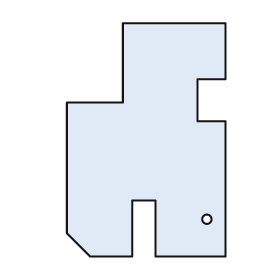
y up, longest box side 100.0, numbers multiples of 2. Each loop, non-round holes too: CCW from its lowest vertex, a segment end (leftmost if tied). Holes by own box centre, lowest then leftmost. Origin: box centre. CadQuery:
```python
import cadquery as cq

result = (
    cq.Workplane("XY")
    .moveTo(-24.0, -50.0)
    .lineTo(-6.0, -50.0)
    .lineTo(-6.0, -26.0)
    .lineTo(4.0, -26.0)
    .lineTo(4.0, -50.0)
    .lineTo(34.0, -50.0)
    .lineTo(34.0, 8.0)
    .lineTo(22.0, 8.0)
    .lineTo(22.0, 26.0)
    .lineTo(34.0, 26.0)
    .lineTo(34.0, 50.0)
    .lineTo(-10.0, 50.0)
    .lineTo(-10.0, 16.0)
    .lineTo(-34.0, 16.0)
    .lineTo(-34.0, -40.0)
    .close()
    .moveTo(26.0, -34.0)
    .circle(2.0)
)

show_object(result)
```